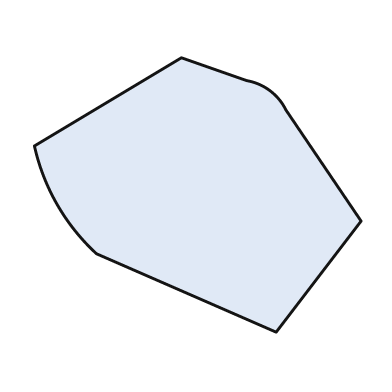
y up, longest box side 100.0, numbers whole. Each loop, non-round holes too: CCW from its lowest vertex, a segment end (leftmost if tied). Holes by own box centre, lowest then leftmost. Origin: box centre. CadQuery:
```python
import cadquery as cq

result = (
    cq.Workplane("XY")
    .moveTo(24.0, -42.0)
    .lineTo(50.0, -8.0)
    .lineTo(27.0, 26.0)
    .threePointArc((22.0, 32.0), (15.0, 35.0))
    .lineTo(-5.0, 42.0)
    .lineTo(-50.0, 15.0)
    .threePointArc((-43.0, -3.0), (-31.0, -18.0))
    .close()
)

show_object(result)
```